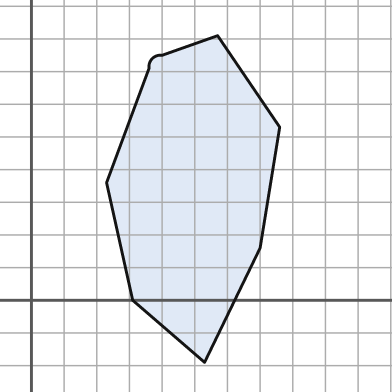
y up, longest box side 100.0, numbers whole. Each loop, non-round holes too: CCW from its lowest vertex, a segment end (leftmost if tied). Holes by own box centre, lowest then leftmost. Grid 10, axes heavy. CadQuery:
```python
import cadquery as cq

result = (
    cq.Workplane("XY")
    .moveTo(53.0, -19.0)
    .lineTo(70.0, 16.0)
    .lineTo(76.0, 53.0)
    .lineTo(57.0, 81.0)
    .lineTo(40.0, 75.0)
    .threePointArc((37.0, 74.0), (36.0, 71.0))
    .lineTo(23.0, 36.0)
    .lineTo(31.0, 0.0)
    .close()
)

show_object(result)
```